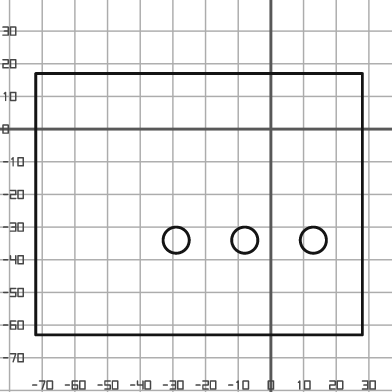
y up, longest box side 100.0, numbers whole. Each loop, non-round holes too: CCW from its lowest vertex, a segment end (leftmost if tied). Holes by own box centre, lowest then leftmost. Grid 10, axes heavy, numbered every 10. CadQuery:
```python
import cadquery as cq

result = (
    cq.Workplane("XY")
    .moveTo(-72.0, -63.0)
    .lineTo(28.0, -63.0)
    .lineTo(28.0, 17.0)
    .lineTo(-72.0, 17.0)
    .close()
    .moveTo(-29.0, -34.0)
    .circle(4.0)
    .moveTo(-8.0, -34.0)
    .circle(4.0)
    .moveTo(13.0, -34.0)
    .circle(4.0)
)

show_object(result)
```